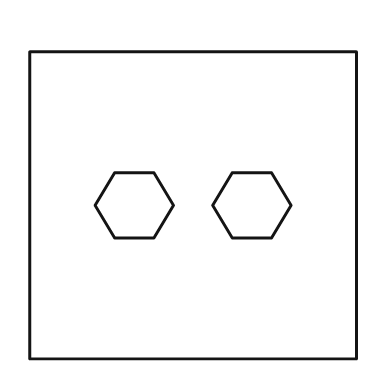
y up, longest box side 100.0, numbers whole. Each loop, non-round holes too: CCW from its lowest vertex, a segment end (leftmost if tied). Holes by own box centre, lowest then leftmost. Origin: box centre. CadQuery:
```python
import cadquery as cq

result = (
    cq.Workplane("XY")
    .moveTo(-50.0, -47.0)
    .lineTo(50.0, -47.0)
    .lineTo(50.0, 47.0)
    .lineTo(-50.0, 47.0)
    .close()
    .moveTo(-24.0, -10.0)
    .lineTo(-12.0, -10.0)
    .lineTo(-6.0, 0.0)
    .lineTo(-12.0, 10.0)
    .lineTo(-24.0, 10.0)
    .lineTo(-30.0, 0.0)
    .close()
    .moveTo(12.0, -10.0)
    .lineTo(24.0, -10.0)
    .lineTo(30.0, 0.0)
    .lineTo(24.0, 10.0)
    .lineTo(12.0, 10.0)
    .lineTo(6.0, 0.0)
    .close()
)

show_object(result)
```